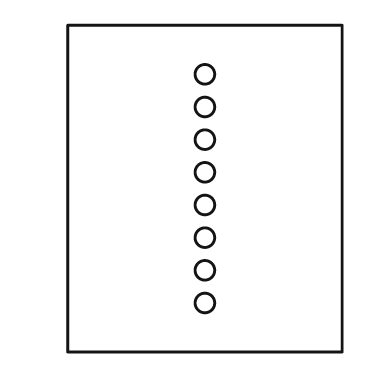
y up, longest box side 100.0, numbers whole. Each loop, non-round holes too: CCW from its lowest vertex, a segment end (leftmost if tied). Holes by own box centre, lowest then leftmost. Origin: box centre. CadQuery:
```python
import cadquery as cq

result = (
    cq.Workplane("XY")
    .moveTo(-42.0, -50.0)
    .lineTo(42.0, -50.0)
    .lineTo(42.0, 50.0)
    .lineTo(-42.0, 50.0)
    .close()
    .moveTo(0.0, -35.0)
    .circle(3.0)
    .moveTo(0.0, -25.0)
    .circle(3.0)
    .moveTo(0.0, -15.0)
    .circle(3.0)
    .moveTo(0.0, -5.0)
    .circle(3.0)
    .moveTo(0.0, 5.0)
    .circle(3.0)
    .moveTo(0.0, 15.0)
    .circle(3.0)
    .moveTo(0.0, 25.0)
    .circle(3.0)
    .moveTo(0.0, 35.0)
    .circle(3.0)
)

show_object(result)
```